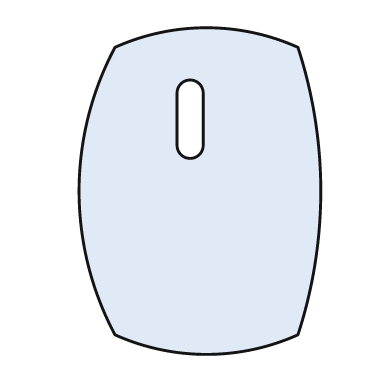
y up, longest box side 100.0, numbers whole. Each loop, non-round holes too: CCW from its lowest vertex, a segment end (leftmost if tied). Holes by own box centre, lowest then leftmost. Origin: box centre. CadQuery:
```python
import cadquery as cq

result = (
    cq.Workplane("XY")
    .moveTo(-26.0, -44.0)
    .threePointArc((2.0, -50.0), (30.0, -44.0))
    .threePointArc((37.0, 0.0), (30.0, 44.0))
    .threePointArc((2.0, 50.0), (-26.0, 44.0))
    .threePointArc((-37.0, 0.0), (-26.0, -44.0))
    .close()
    .moveTo(-7.0, 14.0)
    .threePointArc((-3.0, 10.0), (1.0, 14.0))
    .lineTo(1.0, 30.0)
    .threePointArc((-3.0, 34.0), (-7.0, 30.0))
    .close()
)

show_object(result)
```